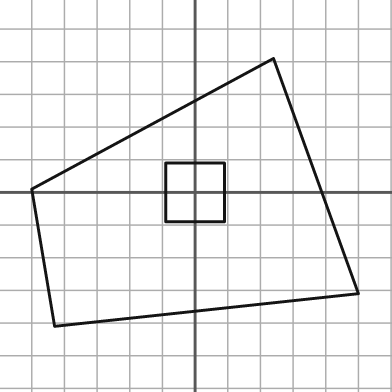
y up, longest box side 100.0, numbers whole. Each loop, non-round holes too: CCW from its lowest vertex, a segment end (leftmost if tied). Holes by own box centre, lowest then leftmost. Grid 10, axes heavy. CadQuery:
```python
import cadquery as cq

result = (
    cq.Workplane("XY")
    .moveTo(-43.0, -41.0)
    .lineTo(50.0, -31.0)
    .lineTo(24.0, 41.0)
    .lineTo(-50.0, 1.0)
    .close()
    .moveTo(-9.0, -9.0)
    .lineTo(9.0, -9.0)
    .lineTo(9.0, 9.0)
    .lineTo(-9.0, 9.0)
    .close()
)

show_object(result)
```